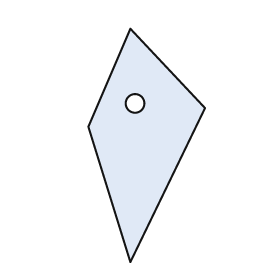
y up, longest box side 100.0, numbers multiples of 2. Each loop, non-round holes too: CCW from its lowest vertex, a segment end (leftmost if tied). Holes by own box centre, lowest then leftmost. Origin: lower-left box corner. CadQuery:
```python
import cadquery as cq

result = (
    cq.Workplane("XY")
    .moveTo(18.0, 0.0)
    .lineTo(50.0, 66.0)
    .lineTo(18.0, 100.0)
    .lineTo(0.0, 58.0)
    .close()
    .moveTo(20.0, 68.0)
    .circle(4.0)
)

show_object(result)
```